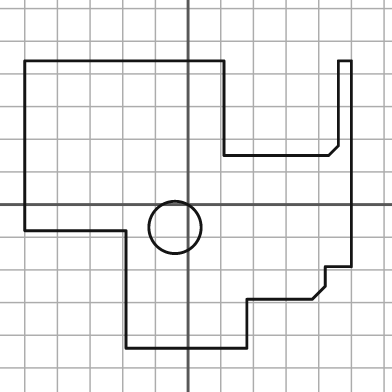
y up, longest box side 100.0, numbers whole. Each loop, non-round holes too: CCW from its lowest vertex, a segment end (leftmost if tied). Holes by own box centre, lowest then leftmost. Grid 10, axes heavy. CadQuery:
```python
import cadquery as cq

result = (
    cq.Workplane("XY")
    .moveTo(-19.0, -44.0)
    .lineTo(18.0, -44.0)
    .lineTo(18.0, -29.0)
    .lineTo(38.0, -29.0)
    .lineTo(42.0, -25.0)
    .lineTo(42.0, -19.0)
    .lineTo(50.0, -19.0)
    .lineTo(50.0, 44.0)
    .lineTo(46.0, 44.0)
    .lineTo(46.0, 18.0)
    .lineTo(43.0, 15.0)
    .lineTo(11.0, 15.0)
    .lineTo(11.0, 44.0)
    .lineTo(-50.0, 44.0)
    .lineTo(-50.0, -8.0)
    .lineTo(-19.0, -8.0)
    .close()
    .moveTo(-4.0, -7.0)
    .circle(8.0)
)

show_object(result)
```